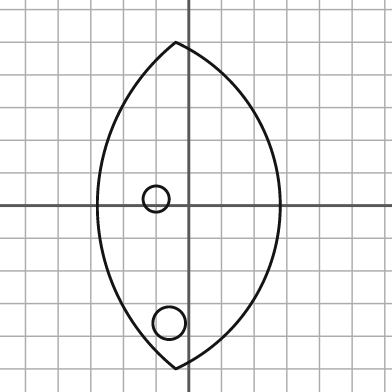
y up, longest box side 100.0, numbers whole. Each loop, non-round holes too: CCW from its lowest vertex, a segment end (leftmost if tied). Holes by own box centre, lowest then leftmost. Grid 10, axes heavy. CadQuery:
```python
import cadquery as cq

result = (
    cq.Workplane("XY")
    .moveTo(-4.0, -50.0)
    .threePointArc((28.0, 0.0), (-4.0, 50.0))
    .threePointArc((-28.0, 0.0), (-4.0, -50.0))
    .close()
    .moveTo(-6.0, -36.0)
    .circle(5.0)
    .moveTo(-10.0, 2.0)
    .circle(4.0)
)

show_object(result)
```